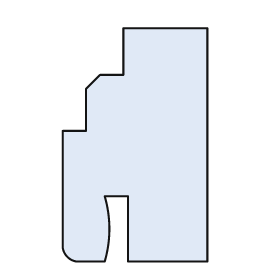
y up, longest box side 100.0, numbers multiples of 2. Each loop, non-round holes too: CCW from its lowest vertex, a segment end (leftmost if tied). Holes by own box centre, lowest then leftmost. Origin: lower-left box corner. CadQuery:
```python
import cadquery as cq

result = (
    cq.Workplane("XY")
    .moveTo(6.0, 0.0)
    .lineTo(18.0, 0.0)
    .threePointArc((20.0, 14.0), (18.0, 28.0))
    .lineTo(28.0, 28.0)
    .lineTo(28.0, 0.0)
    .lineTo(62.0, 0.0)
    .lineTo(62.0, 100.0)
    .lineTo(26.0, 100.0)
    .lineTo(26.0, 80.0)
    .lineTo(16.0, 80.0)
    .lineTo(10.0, 74.0)
    .lineTo(10.0, 56.0)
    .lineTo(0.0, 56.0)
    .lineTo(0.0, 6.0)
    .threePointArc((2.0, 2.0), (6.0, 0.0))
    .close()
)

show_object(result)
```